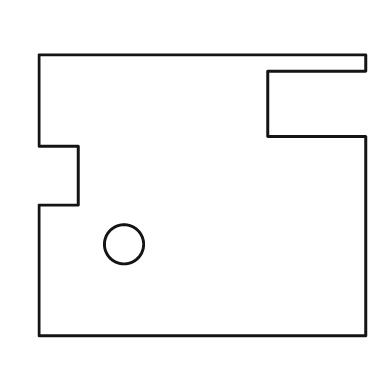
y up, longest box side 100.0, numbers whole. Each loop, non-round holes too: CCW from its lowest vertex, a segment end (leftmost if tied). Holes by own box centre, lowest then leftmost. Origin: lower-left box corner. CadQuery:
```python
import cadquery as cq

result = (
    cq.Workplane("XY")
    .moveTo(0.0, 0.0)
    .lineTo(100.0, 0.0)
    .lineTo(100.0, 61.0)
    .lineTo(70.0, 61.0)
    .lineTo(70.0, 81.0)
    .lineTo(100.0, 81.0)
    .lineTo(100.0, 86.0)
    .lineTo(0.0, 86.0)
    .lineTo(0.0, 58.0)
    .lineTo(12.0, 58.0)
    .lineTo(12.0, 40.0)
    .lineTo(0.0, 40.0)
    .close()
    .moveTo(26.0, 28.0)
    .circle(6.0)
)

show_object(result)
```